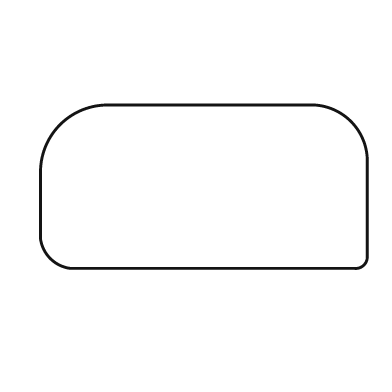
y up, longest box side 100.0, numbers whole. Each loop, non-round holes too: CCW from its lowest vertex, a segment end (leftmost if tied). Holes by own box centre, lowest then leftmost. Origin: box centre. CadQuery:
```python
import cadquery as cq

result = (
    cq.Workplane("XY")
    .moveTo(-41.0, -25.0)
    .lineTo(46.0, -25.0)
    .threePointArc((49.0, -24.0), (50.0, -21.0))
    .lineTo(50.0, 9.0)
    .threePointArc((45.0, 20.0), (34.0, 25.0))
    .lineTo(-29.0, 25.0)
    .threePointArc((-44.0, 19.0), (-50.0, 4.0))
    .lineTo(-50.0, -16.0)
    .threePointArc((-47.0, -22.0), (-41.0, -25.0))
    .close()
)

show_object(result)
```